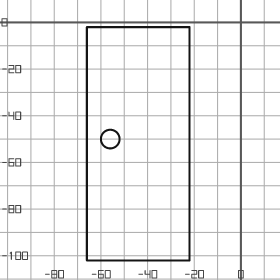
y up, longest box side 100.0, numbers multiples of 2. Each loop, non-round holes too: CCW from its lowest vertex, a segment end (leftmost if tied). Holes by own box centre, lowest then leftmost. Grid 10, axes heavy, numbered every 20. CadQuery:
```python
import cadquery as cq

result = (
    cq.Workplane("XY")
    .moveTo(-66.0, -102.0)
    .lineTo(-22.0, -102.0)
    .lineTo(-22.0, -2.0)
    .lineTo(-66.0, -2.0)
    .close()
    .moveTo(-56.0, -50.0)
    .circle(4.0)
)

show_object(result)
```